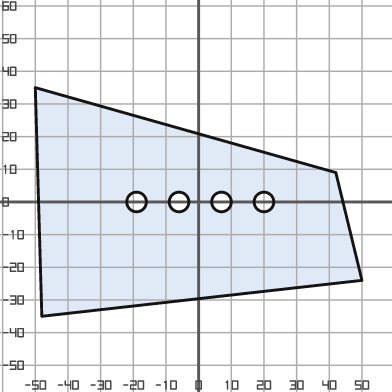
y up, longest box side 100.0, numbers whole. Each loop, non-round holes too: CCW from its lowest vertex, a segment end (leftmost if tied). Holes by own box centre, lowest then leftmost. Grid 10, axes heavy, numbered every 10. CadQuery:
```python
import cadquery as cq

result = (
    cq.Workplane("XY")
    .moveTo(-48.0, -35.0)
    .lineTo(50.0, -24.0)
    .lineTo(42.0, 9.0)
    .lineTo(-50.0, 35.0)
    .close()
    .moveTo(-19.0, 0.0)
    .circle(3.0)
    .moveTo(-6.0, 0.0)
    .circle(3.0)
    .moveTo(7.0, 0.0)
    .circle(3.0)
    .moveTo(20.0, 0.0)
    .circle(3.0)
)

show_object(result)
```